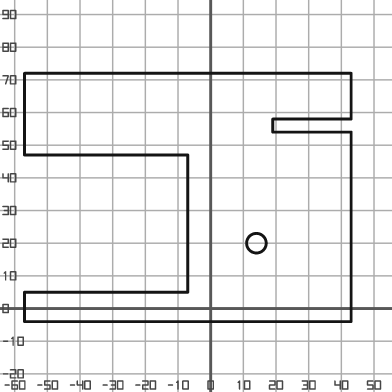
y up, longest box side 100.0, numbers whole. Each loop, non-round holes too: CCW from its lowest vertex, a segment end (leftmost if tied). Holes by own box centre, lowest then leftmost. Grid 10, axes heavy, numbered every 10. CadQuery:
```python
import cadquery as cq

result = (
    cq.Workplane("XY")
    .moveTo(-57.0, -4.0)
    .lineTo(43.0, -4.0)
    .lineTo(43.0, 54.0)
    .lineTo(19.0, 54.0)
    .lineTo(19.0, 58.0)
    .lineTo(43.0, 58.0)
    .lineTo(43.0, 72.0)
    .lineTo(-57.0, 72.0)
    .lineTo(-57.0, 47.0)
    .lineTo(-7.0, 47.0)
    .lineTo(-7.0, 5.0)
    .lineTo(-57.0, 5.0)
    .close()
    .moveTo(14.0, 20.0)
    .circle(3.0)
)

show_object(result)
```